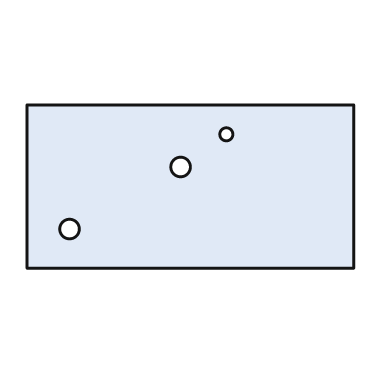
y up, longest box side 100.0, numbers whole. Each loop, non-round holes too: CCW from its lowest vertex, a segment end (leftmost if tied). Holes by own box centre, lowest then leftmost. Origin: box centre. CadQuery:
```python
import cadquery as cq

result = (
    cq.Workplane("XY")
    .moveTo(-50.0, -25.0)
    .lineTo(50.0, -25.0)
    .lineTo(50.0, 25.0)
    .lineTo(-50.0, 25.0)
    .close()
    .moveTo(-37.0, -13.0)
    .circle(3.0)
    .moveTo(-3.0, 6.0)
    .circle(3.0)
    .moveTo(11.0, 16.0)
    .circle(2.0)
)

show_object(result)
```